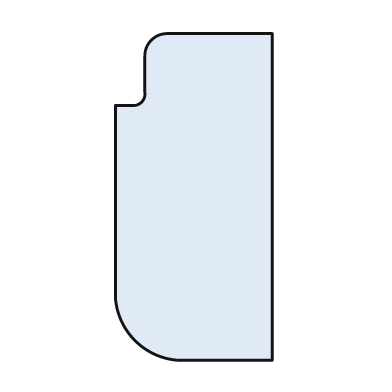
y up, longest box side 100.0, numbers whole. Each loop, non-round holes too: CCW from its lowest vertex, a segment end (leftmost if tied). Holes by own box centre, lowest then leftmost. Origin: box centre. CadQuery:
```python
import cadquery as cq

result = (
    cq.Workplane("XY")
    .moveTo(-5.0, -50.0)
    .lineTo(24.0, -50.0)
    .lineTo(24.0, 50.0)
    .lineTo(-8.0, 50.0)
    .threePointArc((-13.0, 48.0), (-15.0, 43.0))
    .lineTo(-15.0, 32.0)
    .threePointArc((-16.0, 29.0), (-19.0, 28.0))
    .lineTo(-24.0, 28.0)
    .lineTo(-24.0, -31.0)
    .threePointArc((-18.0, -44.0), (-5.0, -50.0))
    .close()
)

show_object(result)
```